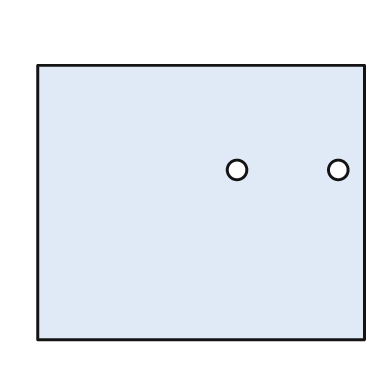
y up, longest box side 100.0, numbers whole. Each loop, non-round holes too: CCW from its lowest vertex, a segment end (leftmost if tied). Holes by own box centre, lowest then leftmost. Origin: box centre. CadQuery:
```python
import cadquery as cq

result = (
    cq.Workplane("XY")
    .moveTo(-50.0, -42.0)
    .lineTo(50.0, -42.0)
    .lineTo(50.0, 42.0)
    .lineTo(-50.0, 42.0)
    .close()
    .moveTo(11.0, 10.0)
    .circle(3.0)
    .moveTo(42.0, 10.0)
    .circle(3.0)
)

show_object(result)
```